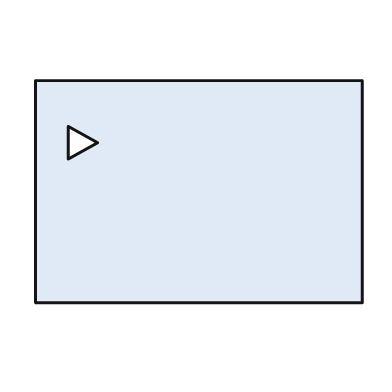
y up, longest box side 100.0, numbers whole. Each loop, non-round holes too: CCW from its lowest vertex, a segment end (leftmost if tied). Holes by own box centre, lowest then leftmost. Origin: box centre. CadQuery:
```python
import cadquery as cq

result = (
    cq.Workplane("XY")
    .moveTo(-50.0, -34.0)
    .lineTo(50.0, -34.0)
    .lineTo(50.0, 34.0)
    .lineTo(-50.0, 34.0)
    .close()
    .moveTo(-40.0, 10.0)
    .lineTo(-31.0, 15.0)
    .lineTo(-40.0, 20.0)
    .close()
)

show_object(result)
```